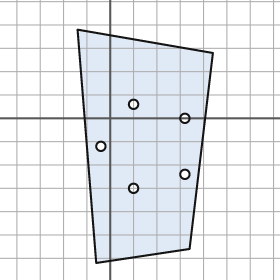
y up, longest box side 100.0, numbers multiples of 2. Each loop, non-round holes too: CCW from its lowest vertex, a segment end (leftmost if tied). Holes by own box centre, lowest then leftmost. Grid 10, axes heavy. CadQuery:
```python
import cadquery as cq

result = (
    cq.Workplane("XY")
    .moveTo(-6.0, -62.0)
    .lineTo(34.0, -56.0)
    .lineTo(44.0, 28.0)
    .lineTo(-14.0, 38.0)
    .close()
    .moveTo(10.0, -30.0)
    .circle(2.0)
    .moveTo(32.0, -24.0)
    .circle(2.0)
    .moveTo(-4.0, -12.0)
    .circle(2.0)
    .moveTo(32.0, 0.0)
    .circle(2.0)
    .moveTo(10.0, 6.0)
    .circle(2.0)
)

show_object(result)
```